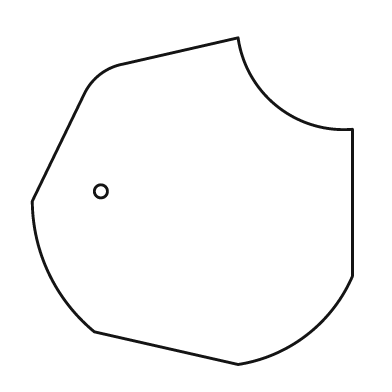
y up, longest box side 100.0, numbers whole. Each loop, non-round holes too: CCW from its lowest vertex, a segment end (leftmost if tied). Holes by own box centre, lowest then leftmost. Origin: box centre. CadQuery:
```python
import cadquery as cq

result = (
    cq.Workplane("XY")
    .moveTo(14.0, -50.0)
    .threePointArc((35.0, -41.0), (49.0, -23.0))
    .lineTo(49.0, 22.0)
    .threePointArc((26.0, 29.0), (14.0, 50.0))
    .lineTo(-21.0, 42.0)
    .threePointArc((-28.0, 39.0), (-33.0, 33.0))
    .lineTo(-49.0, 0.0)
    .threePointArc((-44.0, -22.0), (-30.0, -40.0))
    .close()
    .moveTo(-28.0, 3.0)
    .circle(2.0)
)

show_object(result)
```